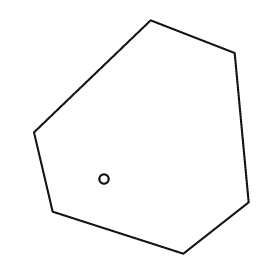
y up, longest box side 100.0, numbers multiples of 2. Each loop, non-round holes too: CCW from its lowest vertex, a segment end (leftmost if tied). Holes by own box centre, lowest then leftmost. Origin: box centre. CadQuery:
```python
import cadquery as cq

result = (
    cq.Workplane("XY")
    .moveTo(18.0, -50.0)
    .lineTo(46.0, -28.0)
    .lineTo(40.0, 36.0)
    .lineTo(4.0, 50.0)
    .lineTo(-46.0, 2.0)
    .lineTo(-38.0, -32.0)
    .close()
    .moveTo(-16.0, -18.0)
    .circle(2.0)
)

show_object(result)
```